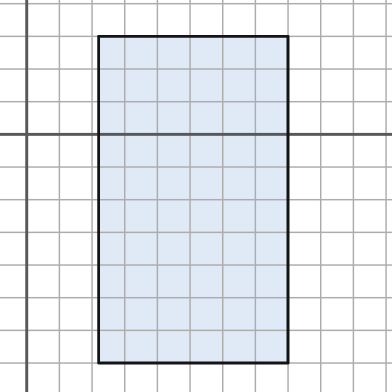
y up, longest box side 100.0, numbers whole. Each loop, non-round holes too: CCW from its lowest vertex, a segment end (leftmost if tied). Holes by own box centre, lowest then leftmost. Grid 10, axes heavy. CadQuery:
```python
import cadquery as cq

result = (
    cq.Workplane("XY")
    .moveTo(22.0, -70.0)
    .lineTo(80.0, -70.0)
    .lineTo(80.0, 30.0)
    .lineTo(22.0, 30.0)
    .close()
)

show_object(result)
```